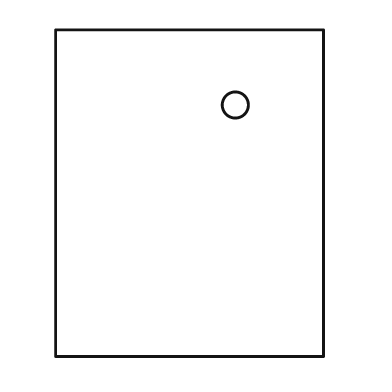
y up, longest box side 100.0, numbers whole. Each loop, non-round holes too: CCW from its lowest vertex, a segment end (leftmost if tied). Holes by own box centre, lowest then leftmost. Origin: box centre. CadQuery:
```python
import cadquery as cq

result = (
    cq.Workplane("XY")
    .moveTo(-41.0, -50.0)
    .lineTo(41.0, -50.0)
    .lineTo(41.0, 50.0)
    .lineTo(-41.0, 50.0)
    .close()
    .moveTo(14.0, 27.0)
    .circle(4.0)
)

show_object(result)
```